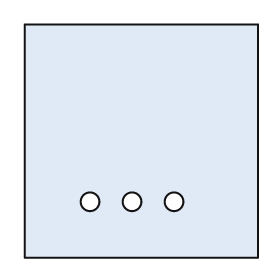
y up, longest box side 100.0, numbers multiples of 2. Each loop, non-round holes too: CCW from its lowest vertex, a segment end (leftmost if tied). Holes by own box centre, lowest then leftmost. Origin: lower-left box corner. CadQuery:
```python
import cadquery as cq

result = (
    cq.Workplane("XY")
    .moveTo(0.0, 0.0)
    .lineTo(100.0, 0.0)
    .lineTo(100.0, 100.0)
    .lineTo(0.0, 100.0)
    .close()
    .moveTo(28.0, 24.0)
    .circle(4.0)
    .moveTo(46.0, 24.0)
    .circle(4.0)
    .moveTo(64.0, 24.0)
    .circle(4.0)
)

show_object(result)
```